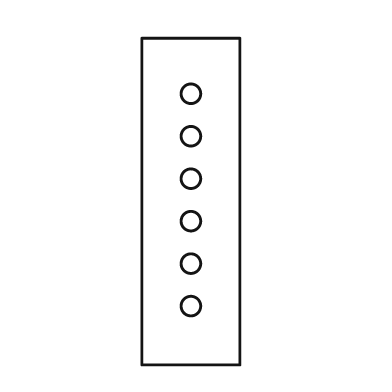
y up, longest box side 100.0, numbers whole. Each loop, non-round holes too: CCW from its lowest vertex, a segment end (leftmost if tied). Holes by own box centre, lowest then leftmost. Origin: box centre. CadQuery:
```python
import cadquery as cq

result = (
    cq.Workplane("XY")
    .moveTo(-15.0, -50.0)
    .lineTo(15.0, -50.0)
    .lineTo(15.0, 50.0)
    .lineTo(-15.0, 50.0)
    .close()
    .moveTo(0.0, -32.0)
    .circle(3.0)
    .moveTo(0.0, -19.0)
    .circle(3.0)
    .moveTo(0.0, -6.0)
    .circle(3.0)
    .moveTo(0.0, 7.0)
    .circle(3.0)
    .moveTo(0.0, 20.0)
    .circle(3.0)
    .moveTo(0.0, 33.0)
    .circle(3.0)
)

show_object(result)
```